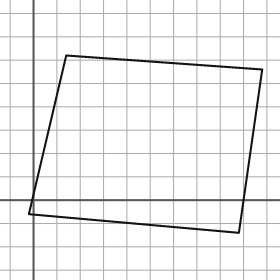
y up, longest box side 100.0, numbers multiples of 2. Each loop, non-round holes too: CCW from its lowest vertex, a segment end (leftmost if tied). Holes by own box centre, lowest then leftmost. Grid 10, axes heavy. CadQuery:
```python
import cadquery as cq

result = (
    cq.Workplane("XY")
    .moveTo(88.0, -14.0)
    .lineTo(98.0, 56.0)
    .lineTo(14.0, 62.0)
    .lineTo(-2.0, -6.0)
    .close()
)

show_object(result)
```